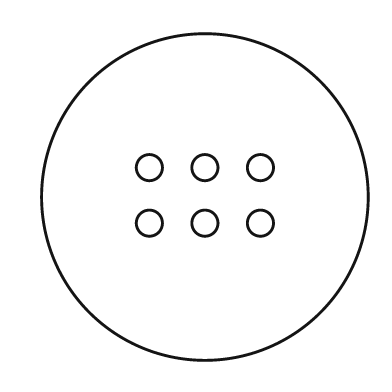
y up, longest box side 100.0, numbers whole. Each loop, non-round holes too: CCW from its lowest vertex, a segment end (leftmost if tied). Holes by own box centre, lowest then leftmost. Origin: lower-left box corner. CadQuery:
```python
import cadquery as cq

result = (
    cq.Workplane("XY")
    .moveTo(50.0, 50.0)
    .circle(50.0)
    .moveTo(33.0, 42.0)
    .circle(4.0)
    .moveTo(50.0, 42.0)
    .circle(4.0)
    .moveTo(67.0, 42.0)
    .circle(4.0)
    .moveTo(33.0, 59.0)
    .circle(4.0)
    .moveTo(50.0, 59.0)
    .circle(4.0)
    .moveTo(67.0, 59.0)
    .circle(4.0)
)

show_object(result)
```